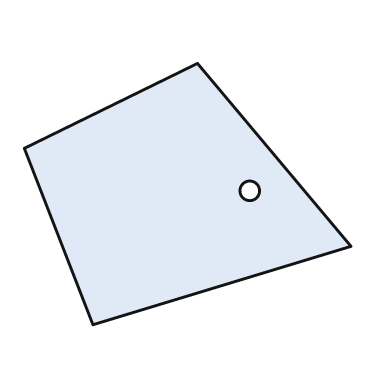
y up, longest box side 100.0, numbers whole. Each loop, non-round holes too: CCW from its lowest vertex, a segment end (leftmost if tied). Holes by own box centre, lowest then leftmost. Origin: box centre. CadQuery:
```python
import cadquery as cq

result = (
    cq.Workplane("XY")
    .moveTo(-29.0, -40.0)
    .lineTo(50.0, -16.0)
    .lineTo(3.0, 40.0)
    .lineTo(-50.0, 14.0)
    .close()
    .moveTo(19.0, 1.0)
    .circle(3.0)
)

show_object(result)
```